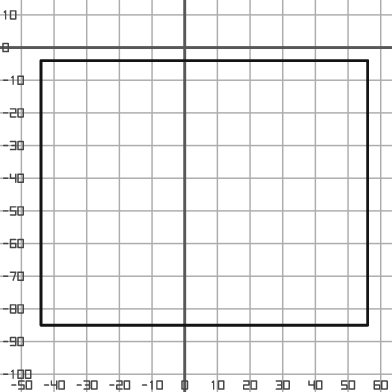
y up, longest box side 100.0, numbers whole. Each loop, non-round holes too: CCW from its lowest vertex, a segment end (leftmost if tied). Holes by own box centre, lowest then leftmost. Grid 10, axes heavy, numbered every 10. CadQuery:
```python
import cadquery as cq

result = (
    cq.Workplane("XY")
    .moveTo(-44.0, -85.0)
    .lineTo(56.0, -85.0)
    .lineTo(56.0, -4.0)
    .lineTo(-44.0, -4.0)
    .close()
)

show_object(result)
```